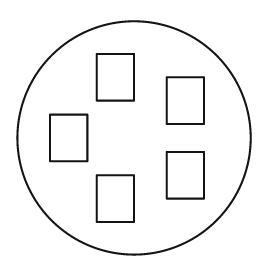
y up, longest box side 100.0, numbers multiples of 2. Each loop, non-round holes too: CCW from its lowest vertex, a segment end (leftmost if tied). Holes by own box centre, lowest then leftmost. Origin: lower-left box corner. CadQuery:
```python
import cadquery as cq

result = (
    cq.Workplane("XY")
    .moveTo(50.0, 50.0)
    .circle(50.0)
    .moveTo(34.0, 14.0)
    .lineTo(50.0, 14.0)
    .lineTo(50.0, 34.0)
    .lineTo(34.0, 34.0)
    .close()
    .moveTo(64.0, 24.0)
    .lineTo(80.0, 24.0)
    .lineTo(80.0, 44.0)
    .lineTo(64.0, 44.0)
    .close()
    .moveTo(14.0, 40.0)
    .lineTo(30.0, 40.0)
    .lineTo(30.0, 60.0)
    .lineTo(14.0, 60.0)
    .close()
    .moveTo(64.0, 56.0)
    .lineTo(80.0, 56.0)
    .lineTo(80.0, 76.0)
    .lineTo(64.0, 76.0)
    .close()
    .moveTo(34.0, 66.0)
    .lineTo(50.0, 66.0)
    .lineTo(50.0, 86.0)
    .lineTo(34.0, 86.0)
    .close()
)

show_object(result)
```